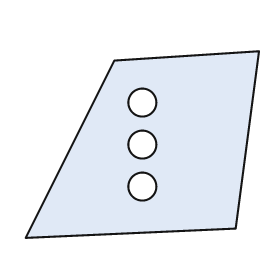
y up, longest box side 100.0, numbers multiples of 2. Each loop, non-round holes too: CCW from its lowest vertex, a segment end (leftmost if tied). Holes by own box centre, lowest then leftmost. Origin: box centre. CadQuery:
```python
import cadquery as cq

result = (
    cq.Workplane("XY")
    .moveTo(-50.0, -40.0)
    .lineTo(40.0, -36.0)
    .lineTo(50.0, 40.0)
    .lineTo(-12.0, 36.0)
    .close()
    .moveTo(0.0, -18.0)
    .circle(6.0)
    .moveTo(0.0, 0.0)
    .circle(6.0)
    .moveTo(0.0, 18.0)
    .circle(6.0)
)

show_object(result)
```